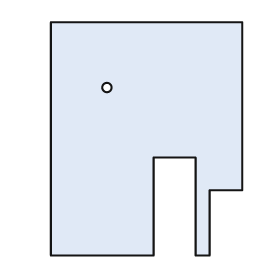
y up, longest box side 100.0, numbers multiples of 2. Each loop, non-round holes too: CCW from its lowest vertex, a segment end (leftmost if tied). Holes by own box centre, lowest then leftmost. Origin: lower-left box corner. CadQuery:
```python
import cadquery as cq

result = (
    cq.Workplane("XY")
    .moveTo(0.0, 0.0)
    .lineTo(44.0, 0.0)
    .lineTo(44.0, 42.0)
    .lineTo(62.0, 42.0)
    .lineTo(62.0, 0.0)
    .lineTo(68.0, 0.0)
    .lineTo(68.0, 28.0)
    .lineTo(82.0, 28.0)
    .lineTo(82.0, 100.0)
    .lineTo(0.0, 100.0)
    .close()
    .moveTo(24.0, 72.0)
    .circle(2.0)
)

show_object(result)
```